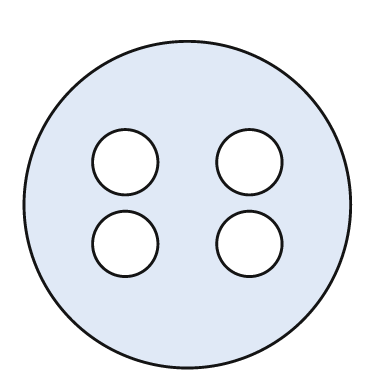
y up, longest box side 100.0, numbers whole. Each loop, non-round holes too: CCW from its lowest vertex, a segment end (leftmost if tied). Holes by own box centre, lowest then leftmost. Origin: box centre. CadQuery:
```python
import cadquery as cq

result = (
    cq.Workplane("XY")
    .moveTo(0.0, 0.0)
    .circle(50.0)
    .moveTo(-19.0, -12.0)
    .circle(10.0)
    .moveTo(19.0, -12.0)
    .circle(10.0)
    .moveTo(-19.0, 13.0)
    .circle(10.0)
    .moveTo(19.0, 13.0)
    .circle(10.0)
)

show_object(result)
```